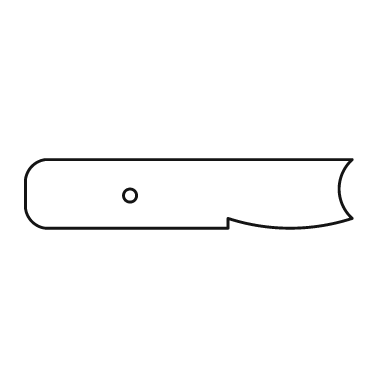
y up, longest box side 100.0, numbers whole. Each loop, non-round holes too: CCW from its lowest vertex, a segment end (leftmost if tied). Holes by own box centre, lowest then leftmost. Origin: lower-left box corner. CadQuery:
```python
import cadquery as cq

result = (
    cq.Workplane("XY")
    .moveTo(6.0, 0.0)
    .lineTo(62.0, 0.0)
    .lineTo(62.0, 3.0)
    .threePointArc((81.0, 0.0), (100.0, 3.0))
    .threePointArc((96.0, 12.0), (100.0, 21.0))
    .lineTo(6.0, 21.0)
    .threePointArc((2.0, 19.0), (0.0, 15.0))
    .lineTo(0.0, 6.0)
    .threePointArc((2.0, 2.0), (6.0, 0.0))
    .close()
    .moveTo(32.0, 10.0)
    .circle(2.0)
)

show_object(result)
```